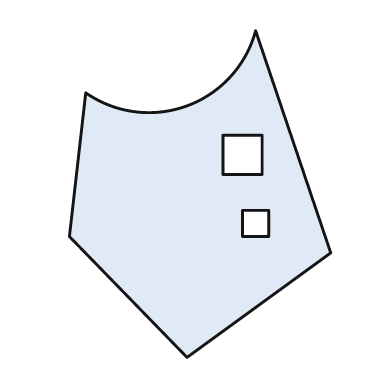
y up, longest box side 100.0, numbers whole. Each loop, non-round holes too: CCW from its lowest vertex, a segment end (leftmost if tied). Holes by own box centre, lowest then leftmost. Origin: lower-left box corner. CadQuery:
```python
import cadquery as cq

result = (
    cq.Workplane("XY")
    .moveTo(36.0, 0.0)
    .lineTo(80.0, 32.0)
    .lineTo(57.0, 100.0)
    .threePointArc((36.0, 77.0), (5.0, 81.0))
    .lineTo(0.0, 37.0)
    .close()
    .moveTo(53.0, 37.0)
    .lineTo(61.0, 37.0)
    .lineTo(61.0, 45.0)
    .lineTo(53.0, 45.0)
    .close()
    .moveTo(47.0, 56.0)
    .lineTo(59.0, 56.0)
    .lineTo(59.0, 68.0)
    .lineTo(47.0, 68.0)
    .close()
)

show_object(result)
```